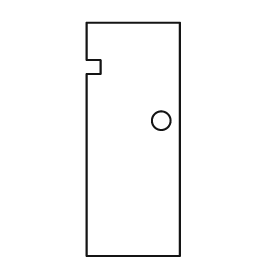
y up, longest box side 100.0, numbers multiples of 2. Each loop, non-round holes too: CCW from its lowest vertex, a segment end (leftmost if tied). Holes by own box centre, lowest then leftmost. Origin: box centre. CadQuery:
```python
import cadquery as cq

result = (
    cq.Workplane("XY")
    .moveTo(-20.0, -50.0)
    .lineTo(20.0, -50.0)
    .lineTo(20.0, 50.0)
    .lineTo(-20.0, 50.0)
    .lineTo(-20.0, 34.0)
    .lineTo(-14.0, 34.0)
    .lineTo(-14.0, 28.0)
    .lineTo(-20.0, 28.0)
    .close()
    .moveTo(12.0, 8.0)
    .circle(4.0)
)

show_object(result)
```